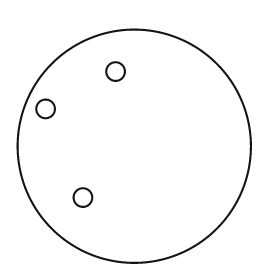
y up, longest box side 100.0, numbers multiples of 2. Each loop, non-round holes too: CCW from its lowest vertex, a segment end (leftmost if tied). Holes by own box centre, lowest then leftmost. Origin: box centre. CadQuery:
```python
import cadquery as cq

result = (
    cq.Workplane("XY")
    .moveTo(0.0, 0.0)
    .circle(50.0)
    .moveTo(-22.0, -22.0)
    .circle(4.0)
    .moveTo(-38.0, 16.0)
    .circle(4.0)
    .moveTo(-8.0, 32.0)
    .circle(4.0)
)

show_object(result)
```